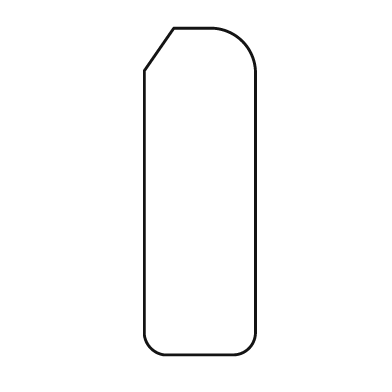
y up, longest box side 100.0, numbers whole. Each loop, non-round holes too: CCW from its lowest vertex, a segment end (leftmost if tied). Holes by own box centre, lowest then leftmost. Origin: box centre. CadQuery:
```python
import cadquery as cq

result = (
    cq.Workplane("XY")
    .moveTo(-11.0, -50.0)
    .lineTo(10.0, -50.0)
    .threePointArc((15.0, -48.0), (17.0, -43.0))
    .lineTo(17.0, 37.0)
    .threePointArc((13.0, 46.0), (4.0, 50.0))
    .lineTo(-8.0, 50.0)
    .lineTo(-17.0, 37.0)
    .lineTo(-17.0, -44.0)
    .threePointArc((-15.0, -48.0), (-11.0, -50.0))
    .close()
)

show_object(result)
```